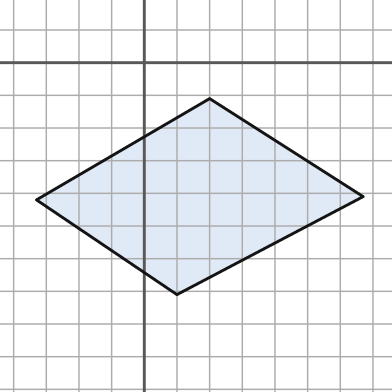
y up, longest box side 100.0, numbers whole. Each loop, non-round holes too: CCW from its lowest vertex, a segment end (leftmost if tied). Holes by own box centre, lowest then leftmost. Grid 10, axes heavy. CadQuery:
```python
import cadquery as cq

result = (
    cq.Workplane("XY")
    .moveTo(10.0, -71.0)
    .lineTo(67.0, -41.0)
    .lineTo(20.0, -11.0)
    .lineTo(-33.0, -42.0)
    .close()
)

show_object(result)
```